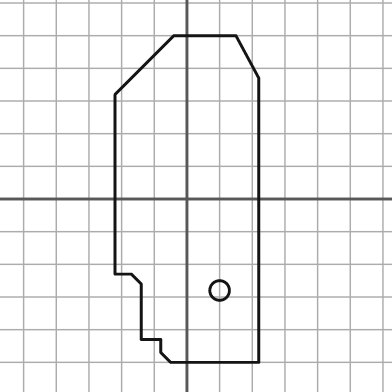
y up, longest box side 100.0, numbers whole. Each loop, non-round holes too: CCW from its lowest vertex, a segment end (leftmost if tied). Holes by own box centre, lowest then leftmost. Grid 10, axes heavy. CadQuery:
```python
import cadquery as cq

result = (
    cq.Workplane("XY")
    .moveTo(-5.0, -50.0)
    .lineTo(22.0, -50.0)
    .lineTo(22.0, 37.0)
    .lineTo(15.0, 50.0)
    .lineTo(-4.0, 50.0)
    .lineTo(-22.0, 32.0)
    .lineTo(-22.0, -23.0)
    .lineTo(-17.0, -23.0)
    .lineTo(-14.0, -26.0)
    .lineTo(-14.0, -43.0)
    .lineTo(-8.0, -43.0)
    .lineTo(-8.0, -47.0)
    .close()
    .moveTo(10.0, -28.0)
    .circle(3.0)
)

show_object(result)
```